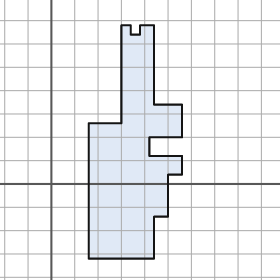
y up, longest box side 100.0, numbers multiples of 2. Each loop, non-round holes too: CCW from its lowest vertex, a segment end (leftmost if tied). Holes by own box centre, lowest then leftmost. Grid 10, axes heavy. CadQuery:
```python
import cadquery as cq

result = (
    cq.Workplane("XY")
    .moveTo(16.0, -32.0)
    .lineTo(44.0, -32.0)
    .lineTo(44.0, -14.0)
    .lineTo(50.0, -14.0)
    .lineTo(50.0, 4.0)
    .lineTo(56.0, 4.0)
    .lineTo(56.0, 12.0)
    .lineTo(42.0, 12.0)
    .lineTo(42.0, 20.0)
    .lineTo(56.0, 20.0)
    .lineTo(56.0, 34.0)
    .lineTo(44.0, 34.0)
    .lineTo(44.0, 68.0)
    .lineTo(38.0, 68.0)
    .lineTo(38.0, 64.0)
    .lineTo(34.0, 64.0)
    .lineTo(34.0, 68.0)
    .lineTo(30.0, 68.0)
    .lineTo(30.0, 26.0)
    .lineTo(16.0, 26.0)
    .close()
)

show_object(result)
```